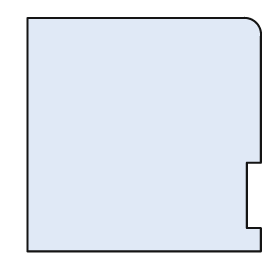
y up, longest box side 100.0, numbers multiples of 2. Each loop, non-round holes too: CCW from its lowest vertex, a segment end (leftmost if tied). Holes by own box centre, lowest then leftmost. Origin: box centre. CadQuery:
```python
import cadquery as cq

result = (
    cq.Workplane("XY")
    .moveTo(-50.0, -50.0)
    .lineTo(50.0, -50.0)
    .lineTo(50.0, -40.0)
    .lineTo(44.0, -40.0)
    .lineTo(44.0, -12.0)
    .lineTo(50.0, -12.0)
    .lineTo(50.0, 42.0)
    .threePointArc((48.0, 48.0), (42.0, 50.0))
    .lineTo(-50.0, 50.0)
    .close()
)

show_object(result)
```